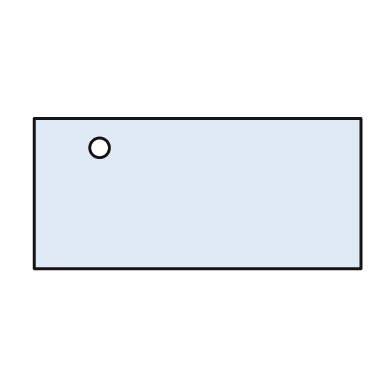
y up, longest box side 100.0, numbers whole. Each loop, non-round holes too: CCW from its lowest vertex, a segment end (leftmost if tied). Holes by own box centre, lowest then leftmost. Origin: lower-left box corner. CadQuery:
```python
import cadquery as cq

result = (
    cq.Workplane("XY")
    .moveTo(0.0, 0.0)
    .lineTo(100.0, 0.0)
    .lineTo(100.0, 46.0)
    .lineTo(0.0, 46.0)
    .close()
    .moveTo(20.0, 37.0)
    .circle(3.0)
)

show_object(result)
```